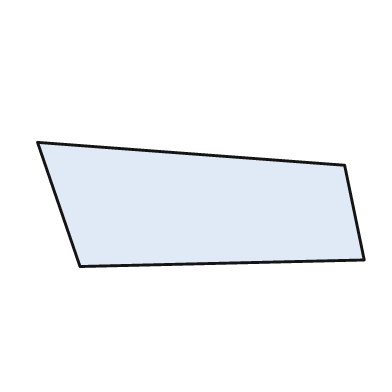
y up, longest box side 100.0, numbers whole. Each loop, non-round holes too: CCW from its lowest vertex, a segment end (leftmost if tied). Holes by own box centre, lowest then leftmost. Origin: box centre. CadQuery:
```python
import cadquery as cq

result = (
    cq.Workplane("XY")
    .moveTo(-37.0, -19.0)
    .lineTo(50.0, -17.0)
    .lineTo(44.0, 12.0)
    .lineTo(-50.0, 19.0)
    .close()
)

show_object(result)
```